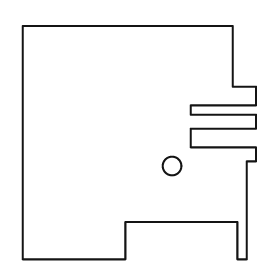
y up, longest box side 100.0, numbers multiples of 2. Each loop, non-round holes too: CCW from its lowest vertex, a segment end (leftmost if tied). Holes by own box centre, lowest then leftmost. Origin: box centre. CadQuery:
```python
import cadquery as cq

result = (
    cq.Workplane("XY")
    .moveTo(-50.0, -50.0)
    .lineTo(-6.0, -50.0)
    .lineTo(-6.0, -34.0)
    .lineTo(42.0, -34.0)
    .lineTo(42.0, -50.0)
    .lineTo(46.0, -50.0)
    .lineTo(46.0, -8.0)
    .lineTo(50.0, -8.0)
    .lineTo(50.0, -2.0)
    .lineTo(22.0, -2.0)
    .lineTo(22.0, 6.0)
    .lineTo(50.0, 6.0)
    .lineTo(50.0, 12.0)
    .lineTo(22.0, 12.0)
    .lineTo(22.0, 16.0)
    .lineTo(50.0, 16.0)
    .lineTo(50.0, 24.0)
    .lineTo(40.0, 24.0)
    .lineTo(40.0, 50.0)
    .lineTo(-50.0, 50.0)
    .close()
    .moveTo(14.0, -10.0)
    .circle(4.0)
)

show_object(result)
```